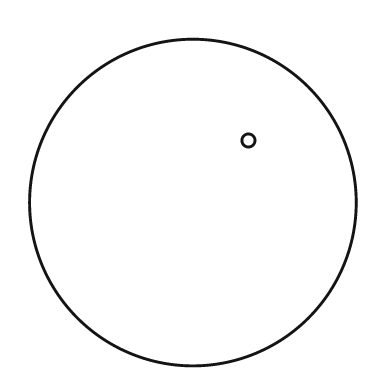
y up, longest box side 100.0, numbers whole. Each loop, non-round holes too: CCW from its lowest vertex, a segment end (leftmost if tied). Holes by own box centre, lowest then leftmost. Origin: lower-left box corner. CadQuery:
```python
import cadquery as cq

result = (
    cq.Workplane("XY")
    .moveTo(50.0, 50.0)
    .circle(50.0)
    .moveTo(67.0, 69.0)
    .circle(2.0)
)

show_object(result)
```